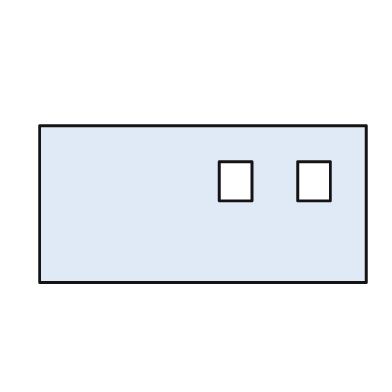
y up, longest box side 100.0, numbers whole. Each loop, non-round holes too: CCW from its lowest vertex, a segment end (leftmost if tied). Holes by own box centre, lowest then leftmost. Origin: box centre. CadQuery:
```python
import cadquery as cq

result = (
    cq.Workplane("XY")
    .moveTo(-50.0, -24.0)
    .lineTo(50.0, -24.0)
    .lineTo(50.0, 24.0)
    .lineTo(-50.0, 24.0)
    .close()
    .moveTo(5.0, 1.0)
    .lineTo(15.0, 1.0)
    .lineTo(15.0, 13.0)
    .lineTo(5.0, 13.0)
    .close()
    .moveTo(29.0, 1.0)
    .lineTo(39.0, 1.0)
    .lineTo(39.0, 13.0)
    .lineTo(29.0, 13.0)
    .close()
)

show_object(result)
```